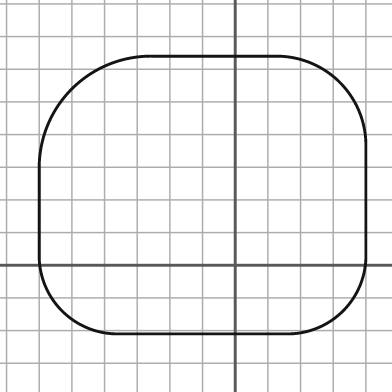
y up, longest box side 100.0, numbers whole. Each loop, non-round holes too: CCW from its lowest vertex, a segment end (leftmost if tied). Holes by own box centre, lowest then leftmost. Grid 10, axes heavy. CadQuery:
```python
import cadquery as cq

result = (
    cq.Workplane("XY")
    .moveTo(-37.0, -21.0)
    .lineTo(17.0, -21.0)
    .threePointArc((33.0, -14.0), (40.0, 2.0))
    .lineTo(40.0, 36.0)
    .threePointArc((32.0, 56.0), (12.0, 64.0))
    .lineTo(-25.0, 64.0)
    .threePointArc((-50.0, 54.0), (-60.0, 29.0))
    .lineTo(-60.0, 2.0)
    .threePointArc((-53.0, -14.0), (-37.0, -21.0))
    .close()
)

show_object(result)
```